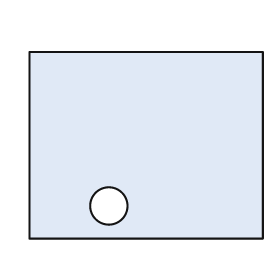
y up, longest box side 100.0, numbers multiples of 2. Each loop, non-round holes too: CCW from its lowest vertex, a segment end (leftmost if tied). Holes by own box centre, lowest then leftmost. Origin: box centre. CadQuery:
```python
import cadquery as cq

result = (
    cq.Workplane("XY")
    .moveTo(-50.0, -40.0)
    .lineTo(50.0, -40.0)
    .lineTo(50.0, 40.0)
    .lineTo(-50.0, 40.0)
    .close()
    .moveTo(-16.0, -26.0)
    .circle(8.0)
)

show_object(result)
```